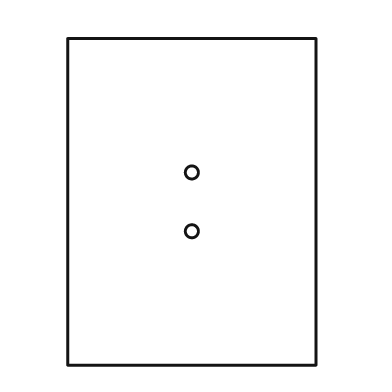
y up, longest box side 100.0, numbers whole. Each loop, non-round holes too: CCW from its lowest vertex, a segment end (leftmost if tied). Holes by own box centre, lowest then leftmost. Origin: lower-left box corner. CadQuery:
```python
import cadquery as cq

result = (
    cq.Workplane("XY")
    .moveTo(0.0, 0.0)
    .lineTo(76.0, 0.0)
    .lineTo(76.0, 100.0)
    .lineTo(0.0, 100.0)
    .close()
    .moveTo(38.0, 41.0)
    .circle(2.0)
    .moveTo(38.0, 59.0)
    .circle(2.0)
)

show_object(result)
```